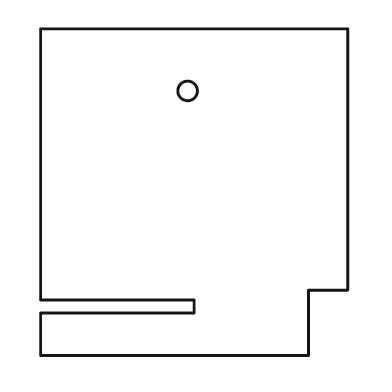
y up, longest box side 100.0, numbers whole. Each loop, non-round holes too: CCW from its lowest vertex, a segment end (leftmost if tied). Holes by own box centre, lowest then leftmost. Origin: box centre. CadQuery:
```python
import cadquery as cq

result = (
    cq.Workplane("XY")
    .moveTo(-47.0, -50.0)
    .lineTo(35.0, -50.0)
    .lineTo(35.0, -30.0)
    .lineTo(47.0, -30.0)
    .lineTo(47.0, 50.0)
    .lineTo(-47.0, 50.0)
    .lineTo(-47.0, -33.0)
    .lineTo(0.0, -33.0)
    .lineTo(0.0, -37.0)
    .lineTo(-47.0, -37.0)
    .close()
    .moveTo(-2.0, 31.0)
    .circle(3.0)
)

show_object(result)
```